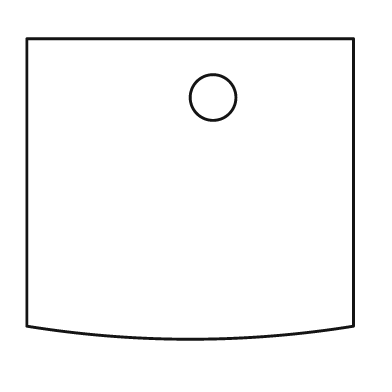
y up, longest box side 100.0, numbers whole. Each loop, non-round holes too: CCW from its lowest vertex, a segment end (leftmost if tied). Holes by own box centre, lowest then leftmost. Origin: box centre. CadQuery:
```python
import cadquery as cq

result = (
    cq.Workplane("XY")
    .moveTo(-50.0, -42.0)
    .threePointArc((0.0, -46.0), (50.0, -42.0))
    .lineTo(50.0, 46.0)
    .lineTo(-50.0, 46.0)
    .close()
    .moveTo(7.0, 28.0)
    .circle(7.0)
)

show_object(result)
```